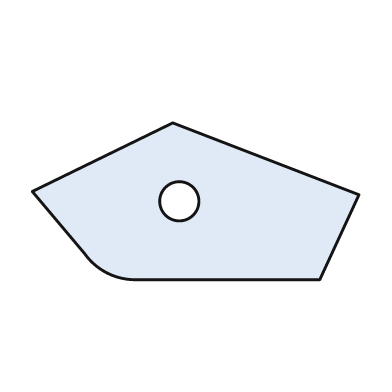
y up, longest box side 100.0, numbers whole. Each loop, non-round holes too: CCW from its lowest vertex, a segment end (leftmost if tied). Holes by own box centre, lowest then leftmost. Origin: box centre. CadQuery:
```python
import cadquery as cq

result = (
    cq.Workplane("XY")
    .moveTo(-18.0, -24.0)
    .lineTo(38.0, -24.0)
    .lineTo(50.0, 2.0)
    .lineTo(-7.0, 24.0)
    .lineTo(-50.0, 3.0)
    .lineTo(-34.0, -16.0)
    .threePointArc((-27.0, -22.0), (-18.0, -24.0))
    .close()
    .moveTo(-5.0, 0.0)
    .circle(6.0)
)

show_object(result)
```